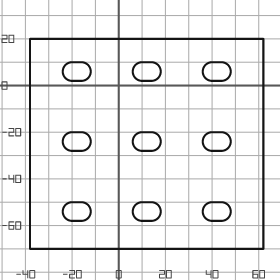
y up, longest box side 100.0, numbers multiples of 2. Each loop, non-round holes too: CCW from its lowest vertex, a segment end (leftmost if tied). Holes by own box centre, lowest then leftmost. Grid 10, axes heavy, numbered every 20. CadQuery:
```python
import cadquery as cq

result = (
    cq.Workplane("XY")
    .moveTo(-38.0, -70.0)
    .lineTo(62.0, -70.0)
    .lineTo(62.0, 20.0)
    .lineTo(-38.0, 20.0)
    .close()
    .moveTo(-20.0, -58.0)
    .lineTo(-16.0, -58.0)
    .threePointArc((-12.0, -54.0), (-16.0, -50.0))
    .lineTo(-20.0, -50.0)
    .threePointArc((-24.0, -54.0), (-20.0, -58.0))
    .close()
    .moveTo(10.0, -58.0)
    .lineTo(14.0, -58.0)
    .threePointArc((18.0, -54.0), (14.0, -50.0))
    .lineTo(10.0, -50.0)
    .threePointArc((6.0, -54.0), (10.0, -58.0))
    .close()
    .moveTo(40.0, -58.0)
    .lineTo(44.0, -58.0)
    .threePointArc((48.0, -54.0), (44.0, -50.0))
    .lineTo(40.0, -50.0)
    .threePointArc((36.0, -54.0), (40.0, -58.0))
    .close()
    .moveTo(-20.0, -28.0)
    .lineTo(-16.0, -28.0)
    .threePointArc((-12.0, -24.0), (-16.0, -20.0))
    .lineTo(-20.0, -20.0)
    .threePointArc((-24.0, -24.0), (-20.0, -28.0))
    .close()
    .moveTo(10.0, -28.0)
    .lineTo(14.0, -28.0)
    .threePointArc((18.0, -24.0), (14.0, -20.0))
    .lineTo(10.0, -20.0)
    .threePointArc((6.0, -24.0), (10.0, -28.0))
    .close()
    .moveTo(40.0, -28.0)
    .lineTo(44.0, -28.0)
    .threePointArc((48.0, -24.0), (44.0, -20.0))
    .lineTo(40.0, -20.0)
    .threePointArc((36.0, -24.0), (40.0, -28.0))
    .close()
    .moveTo(-20.0, 2.0)
    .lineTo(-16.0, 2.0)
    .threePointArc((-12.0, 6.0), (-16.0, 10.0))
    .lineTo(-20.0, 10.0)
    .threePointArc((-24.0, 6.0), (-20.0, 2.0))
    .close()
    .moveTo(10.0, 2.0)
    .lineTo(14.0, 2.0)
    .threePointArc((18.0, 6.0), (14.0, 10.0))
    .lineTo(10.0, 10.0)
    .threePointArc((6.0, 6.0), (10.0, 2.0))
    .close()
    .moveTo(40.0, 2.0)
    .lineTo(44.0, 2.0)
    .threePointArc((48.0, 6.0), (44.0, 10.0))
    .lineTo(40.0, 10.0)
    .threePointArc((36.0, 6.0), (40.0, 2.0))
    .close()
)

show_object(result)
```